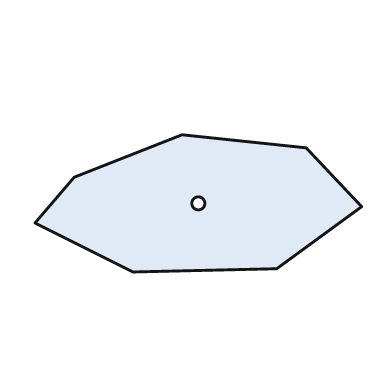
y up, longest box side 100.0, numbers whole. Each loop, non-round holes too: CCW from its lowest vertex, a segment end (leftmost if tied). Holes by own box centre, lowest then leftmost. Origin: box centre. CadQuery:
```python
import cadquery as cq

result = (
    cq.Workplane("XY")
    .moveTo(-20.0, -21.0)
    .lineTo(24.0, -20.0)
    .lineTo(50.0, -1.0)
    .lineTo(33.0, 17.0)
    .lineTo(-5.0, 21.0)
    .lineTo(-38.0, 8.0)
    .lineTo(-50.0, -6.0)
    .close()
    .moveTo(0.0, 0.0)
    .circle(2.0)
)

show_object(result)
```